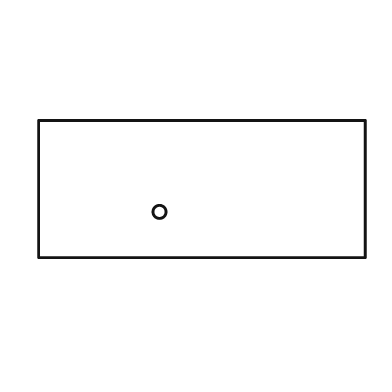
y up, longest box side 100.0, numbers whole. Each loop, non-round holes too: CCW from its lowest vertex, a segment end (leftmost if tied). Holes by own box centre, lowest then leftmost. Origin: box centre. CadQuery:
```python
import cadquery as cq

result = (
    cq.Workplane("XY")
    .moveTo(-50.0, -21.0)
    .lineTo(50.0, -21.0)
    .lineTo(50.0, 21.0)
    .lineTo(-50.0, 21.0)
    .close()
    .moveTo(-13.0, -7.0)
    .circle(2.0)
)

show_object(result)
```